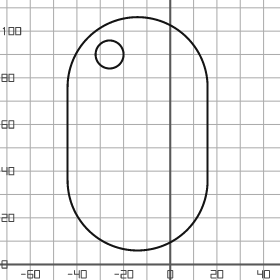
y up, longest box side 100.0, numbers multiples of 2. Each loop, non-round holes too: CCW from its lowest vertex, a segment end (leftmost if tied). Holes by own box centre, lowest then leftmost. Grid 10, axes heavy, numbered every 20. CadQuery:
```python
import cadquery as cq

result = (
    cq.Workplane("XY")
    .moveTo(-44.0, 36.0)
    .threePointArc((-14.0, 6.0), (16.0, 36.0))
    .lineTo(16.0, 76.0)
    .threePointArc((-14.0, 106.0), (-44.0, 76.0))
    .close()
    .moveTo(-26.0, 90.0)
    .circle(6.0)
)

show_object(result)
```